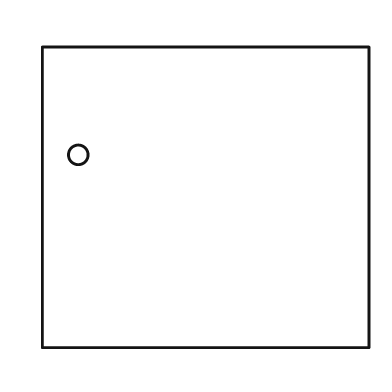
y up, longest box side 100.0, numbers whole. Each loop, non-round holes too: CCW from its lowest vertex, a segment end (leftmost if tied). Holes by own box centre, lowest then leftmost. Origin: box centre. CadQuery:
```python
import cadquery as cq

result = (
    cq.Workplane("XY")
    .moveTo(-50.0, -46.0)
    .lineTo(50.0, -46.0)
    .lineTo(50.0, 46.0)
    .lineTo(-50.0, 46.0)
    .close()
    .moveTo(-39.0, 13.0)
    .circle(3.0)
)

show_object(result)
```